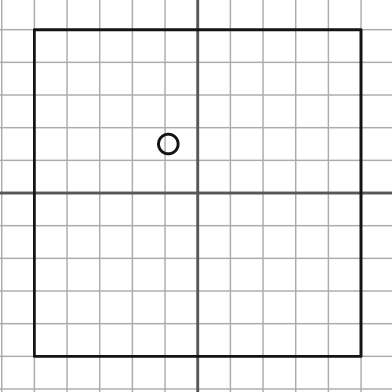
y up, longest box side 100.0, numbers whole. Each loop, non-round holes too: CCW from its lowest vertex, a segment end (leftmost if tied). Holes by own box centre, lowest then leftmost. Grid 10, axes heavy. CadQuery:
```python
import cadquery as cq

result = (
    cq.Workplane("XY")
    .moveTo(-50.0, -50.0)
    .lineTo(50.0, -50.0)
    .lineTo(50.0, 50.0)
    .lineTo(-50.0, 50.0)
    .close()
    .moveTo(-9.0, 15.0)
    .circle(3.0)
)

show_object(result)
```